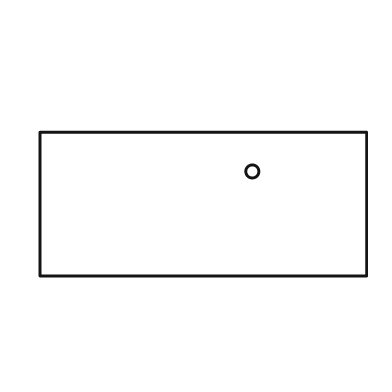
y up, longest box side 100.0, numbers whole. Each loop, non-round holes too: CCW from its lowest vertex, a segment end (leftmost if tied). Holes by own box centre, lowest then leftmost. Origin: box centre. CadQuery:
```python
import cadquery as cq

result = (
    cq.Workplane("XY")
    .moveTo(-50.0, -22.0)
    .lineTo(50.0, -22.0)
    .lineTo(50.0, 22.0)
    .lineTo(-50.0, 22.0)
    .close()
    .moveTo(15.0, 10.0)
    .circle(2.0)
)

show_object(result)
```